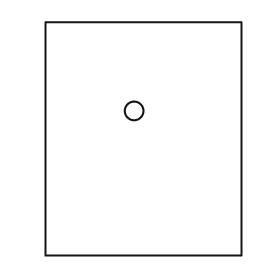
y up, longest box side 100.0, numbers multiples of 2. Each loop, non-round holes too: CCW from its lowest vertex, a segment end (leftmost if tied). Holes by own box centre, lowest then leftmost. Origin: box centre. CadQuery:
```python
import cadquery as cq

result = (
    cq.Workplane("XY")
    .moveTo(-42.0, -50.0)
    .lineTo(42.0, -50.0)
    .lineTo(42.0, 50.0)
    .lineTo(-42.0, 50.0)
    .close()
    .moveTo(-4.0, 12.0)
    .circle(4.0)
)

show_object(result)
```